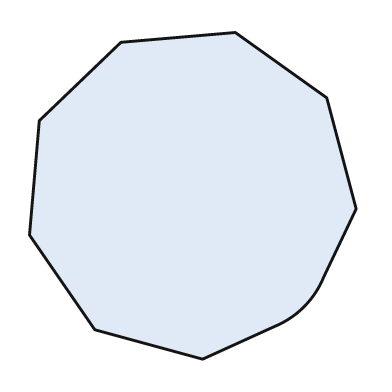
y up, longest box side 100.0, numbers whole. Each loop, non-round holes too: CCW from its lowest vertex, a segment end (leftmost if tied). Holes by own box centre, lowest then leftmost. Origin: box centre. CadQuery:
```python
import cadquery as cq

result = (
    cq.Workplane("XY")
    .moveTo(3.0, -50.0)
    .lineTo(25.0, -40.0)
    .threePointArc((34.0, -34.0), (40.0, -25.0))
    .lineTo(50.0, -4.0)
    .lineTo(41.0, 30.0)
    .lineTo(13.0, 50.0)
    .lineTo(-22.0, 47.0)
    .lineTo(-47.0, 23.0)
    .lineTo(-50.0, -12.0)
    .lineTo(-30.0, -41.0)
    .close()
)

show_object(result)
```